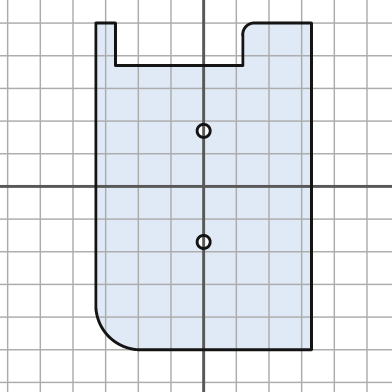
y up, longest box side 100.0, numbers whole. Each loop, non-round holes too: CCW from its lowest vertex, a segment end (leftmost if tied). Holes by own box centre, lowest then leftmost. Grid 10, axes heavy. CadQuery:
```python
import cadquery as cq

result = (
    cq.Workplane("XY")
    .moveTo(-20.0, -50.0)
    .lineTo(33.0, -50.0)
    .lineTo(33.0, 50.0)
    .lineTo(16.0, 50.0)
    .threePointArc((13.0, 49.0), (12.0, 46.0))
    .lineTo(12.0, 37.0)
    .lineTo(-27.0, 37.0)
    .lineTo(-27.0, 50.0)
    .lineTo(-33.0, 50.0)
    .lineTo(-33.0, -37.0)
    .threePointArc((-29.0, -46.0), (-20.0, -50.0))
    .close()
    .moveTo(0.0, -17.0)
    .circle(2.0)
    .moveTo(0.0, 17.0)
    .circle(2.0)
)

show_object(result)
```